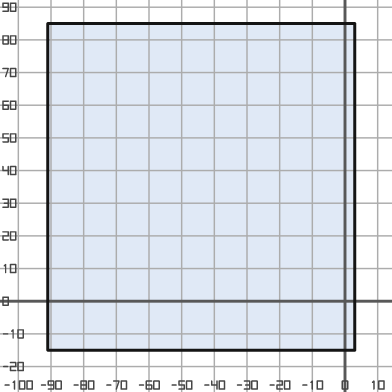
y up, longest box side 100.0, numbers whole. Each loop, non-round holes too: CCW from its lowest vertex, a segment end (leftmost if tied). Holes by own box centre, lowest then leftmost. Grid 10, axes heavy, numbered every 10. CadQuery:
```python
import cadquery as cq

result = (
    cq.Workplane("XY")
    .moveTo(-91.0, -15.0)
    .lineTo(3.0, -15.0)
    .lineTo(3.0, 85.0)
    .lineTo(-91.0, 85.0)
    .close()
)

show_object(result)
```